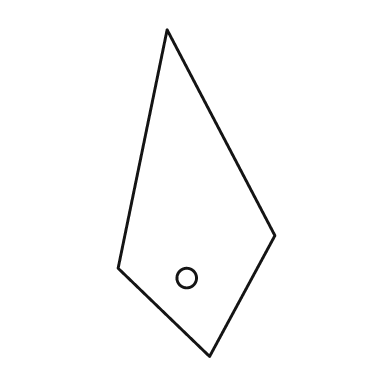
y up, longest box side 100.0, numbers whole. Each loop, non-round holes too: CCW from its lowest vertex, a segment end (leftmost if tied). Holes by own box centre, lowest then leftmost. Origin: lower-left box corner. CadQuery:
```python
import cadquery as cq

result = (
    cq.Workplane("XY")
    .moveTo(28.0, 0.0)
    .lineTo(48.0, 37.0)
    .lineTo(15.0, 100.0)
    .lineTo(0.0, 27.0)
    .close()
    .moveTo(21.0, 24.0)
    .circle(3.0)
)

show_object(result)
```